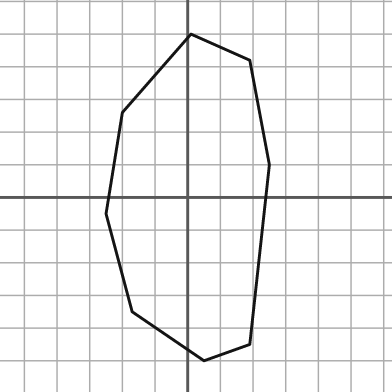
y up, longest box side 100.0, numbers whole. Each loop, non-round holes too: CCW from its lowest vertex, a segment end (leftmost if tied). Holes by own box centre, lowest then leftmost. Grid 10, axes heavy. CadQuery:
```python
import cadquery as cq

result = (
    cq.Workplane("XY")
    .moveTo(5.0, -50.0)
    .lineTo(19.0, -45.0)
    .lineTo(25.0, 10.0)
    .lineTo(19.0, 42.0)
    .lineTo(1.0, 50.0)
    .lineTo(-20.0, 26.0)
    .lineTo(-25.0, -5.0)
    .lineTo(-17.0, -35.0)
    .close()
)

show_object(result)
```